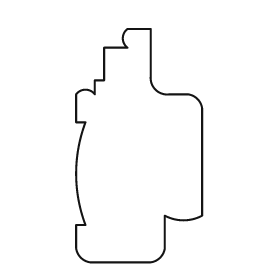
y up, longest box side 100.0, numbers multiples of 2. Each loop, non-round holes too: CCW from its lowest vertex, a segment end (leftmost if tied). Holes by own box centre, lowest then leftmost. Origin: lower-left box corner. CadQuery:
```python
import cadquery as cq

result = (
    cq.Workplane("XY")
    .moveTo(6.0, 0.0)
    .lineTo(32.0, 0.0)
    .threePointArc((36.0, 2.0), (38.0, 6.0))
    .lineTo(38.0, 20.0)
    .threePointArc((46.0, 18.0), (54.0, 20.0))
    .lineTo(54.0, 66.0)
    .threePointArc((52.0, 70.0), (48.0, 72.0))
    .lineTo(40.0, 72.0)
    .threePointArc((34.0, 74.0), (32.0, 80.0))
    .lineTo(32.0, 100.0)
    .lineTo(22.0, 100.0)
    .threePointArc((20.0, 96.0), (22.0, 92.0))
    .lineTo(12.0, 92.0)
    .lineTo(12.0, 78.0)
    .lineTo(8.0, 78.0)
    .lineTo(8.0, 72.0)
    .threePointArc((4.0, 74.0), (0.0, 72.0))
    .lineTo(0.0, 60.0)
    .lineTo(4.0, 60.0)
    .threePointArc((0.0, 38.0), (4.0, 16.0))
    .lineTo(0.0, 16.0)
    .lineTo(0.0, 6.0)
    .threePointArc((2.0, 2.0), (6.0, 0.0))
    .close()
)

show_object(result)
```